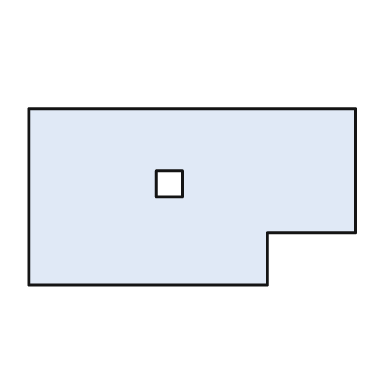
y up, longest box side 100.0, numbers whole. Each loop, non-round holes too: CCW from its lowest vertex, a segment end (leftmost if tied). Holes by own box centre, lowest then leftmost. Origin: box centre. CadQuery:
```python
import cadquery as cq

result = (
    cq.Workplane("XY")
    .moveTo(-50.0, -27.0)
    .lineTo(23.0, -27.0)
    .lineTo(23.0, -11.0)
    .lineTo(50.0, -11.0)
    .lineTo(50.0, 27.0)
    .lineTo(-50.0, 27.0)
    .close()
    .moveTo(-11.0, 0.0)
    .lineTo(-3.0, 0.0)
    .lineTo(-3.0, 8.0)
    .lineTo(-11.0, 8.0)
    .close()
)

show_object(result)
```